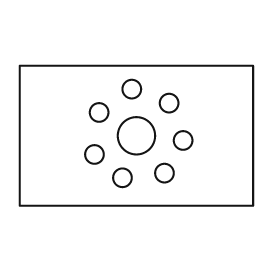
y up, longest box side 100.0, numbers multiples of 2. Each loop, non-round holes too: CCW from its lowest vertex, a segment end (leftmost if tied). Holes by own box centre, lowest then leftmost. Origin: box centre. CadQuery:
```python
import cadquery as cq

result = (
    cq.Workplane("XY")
    .moveTo(-50.0, -30.0)
    .lineTo(50.0, -30.0)
    .lineTo(50.0, 30.0)
    .lineTo(-50.0, 30.0)
    .close()
    .moveTo(-6.0, -18.0)
    .circle(4.0)
    .moveTo(12.0, -16.0)
    .circle(4.0)
    .moveTo(-18.0, -8.0)
    .circle(4.0)
    .moveTo(20.0, -2.0)
    .circle(4.0)
    .moveTo(0.0, 0.0)
    .circle(8.0)
    .moveTo(-16.0, 10.0)
    .circle(4.0)
    .moveTo(14.0, 14.0)
    .circle(4.0)
    .moveTo(-2.0, 20.0)
    .circle(4.0)
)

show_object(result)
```